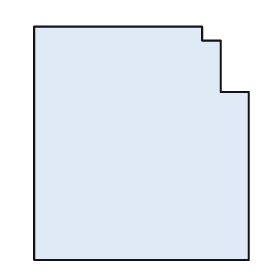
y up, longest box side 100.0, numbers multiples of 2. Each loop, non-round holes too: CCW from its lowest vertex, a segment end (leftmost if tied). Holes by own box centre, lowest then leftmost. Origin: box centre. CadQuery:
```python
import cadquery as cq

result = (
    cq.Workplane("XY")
    .moveTo(-46.0, -50.0)
    .lineTo(46.0, -50.0)
    .lineTo(46.0, 22.0)
    .lineTo(34.0, 22.0)
    .lineTo(34.0, 44.0)
    .lineTo(26.0, 44.0)
    .lineTo(26.0, 50.0)
    .lineTo(-46.0, 50.0)
    .close()
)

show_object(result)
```